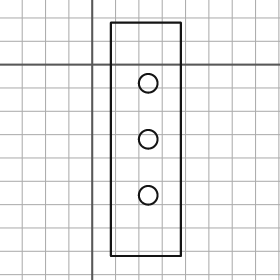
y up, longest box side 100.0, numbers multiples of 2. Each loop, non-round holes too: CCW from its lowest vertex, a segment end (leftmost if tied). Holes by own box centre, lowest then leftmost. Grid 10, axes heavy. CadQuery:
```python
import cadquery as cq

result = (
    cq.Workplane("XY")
    .moveTo(8.0, -82.0)
    .lineTo(38.0, -82.0)
    .lineTo(38.0, 18.0)
    .lineTo(8.0, 18.0)
    .close()
    .moveTo(24.0, -56.0)
    .circle(4.0)
    .moveTo(24.0, -32.0)
    .circle(4.0)
    .moveTo(24.0, -8.0)
    .circle(4.0)
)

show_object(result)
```